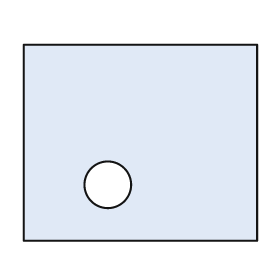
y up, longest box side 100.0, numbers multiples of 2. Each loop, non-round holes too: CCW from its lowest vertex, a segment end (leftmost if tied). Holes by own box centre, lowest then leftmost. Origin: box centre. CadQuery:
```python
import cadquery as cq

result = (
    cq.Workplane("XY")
    .moveTo(-50.0, -42.0)
    .lineTo(50.0, -42.0)
    .lineTo(50.0, 42.0)
    .lineTo(-50.0, 42.0)
    .close()
    .moveTo(-14.0, -18.0)
    .circle(10.0)
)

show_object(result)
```